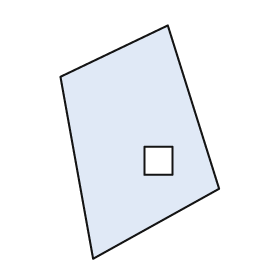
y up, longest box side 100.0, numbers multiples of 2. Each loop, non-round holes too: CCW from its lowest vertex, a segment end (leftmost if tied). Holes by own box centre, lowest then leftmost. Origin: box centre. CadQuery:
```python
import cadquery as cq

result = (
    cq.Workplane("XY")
    .moveTo(-20.0, -50.0)
    .lineTo(34.0, -20.0)
    .lineTo(12.0, 50.0)
    .lineTo(-34.0, 28.0)
    .close()
    .moveTo(2.0, -14.0)
    .lineTo(14.0, -14.0)
    .lineTo(14.0, -2.0)
    .lineTo(2.0, -2.0)
    .close()
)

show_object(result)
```